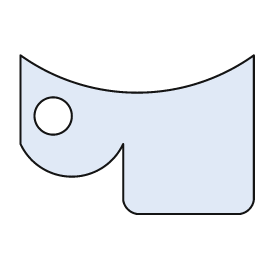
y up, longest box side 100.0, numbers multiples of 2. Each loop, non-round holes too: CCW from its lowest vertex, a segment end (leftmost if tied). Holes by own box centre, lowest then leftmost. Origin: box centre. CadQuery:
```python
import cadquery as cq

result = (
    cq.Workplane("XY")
    .moveTo(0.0, -34.0)
    .lineTo(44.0, -34.0)
    .threePointArc((48.0, -32.0), (50.0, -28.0))
    .lineTo(50.0, 34.0)
    .threePointArc((0.0, 18.0), (-50.0, 34.0))
    .lineTo(-50.0, -4.0)
    .threePointArc((-28.0, -18.0), (-6.0, -4.0))
    .lineTo(-6.0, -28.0)
    .threePointArc((-4.0, -32.0), (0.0, -34.0))
    .close()
    .moveTo(-36.0, 8.0)
    .circle(8.0)
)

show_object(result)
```